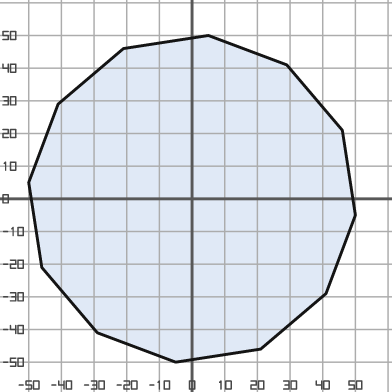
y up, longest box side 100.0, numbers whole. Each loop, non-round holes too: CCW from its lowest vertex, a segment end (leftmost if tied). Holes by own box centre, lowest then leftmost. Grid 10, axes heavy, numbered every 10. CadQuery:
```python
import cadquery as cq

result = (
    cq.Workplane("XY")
    .moveTo(-5.0, -50.0)
    .lineTo(21.0, -46.0)
    .lineTo(41.0, -29.0)
    .lineTo(50.0, -5.0)
    .lineTo(46.0, 21.0)
    .lineTo(29.0, 41.0)
    .lineTo(5.0, 50.0)
    .lineTo(-21.0, 46.0)
    .lineTo(-41.0, 29.0)
    .lineTo(-50.0, 5.0)
    .lineTo(-46.0, -21.0)
    .lineTo(-29.0, -41.0)
    .close()
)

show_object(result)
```